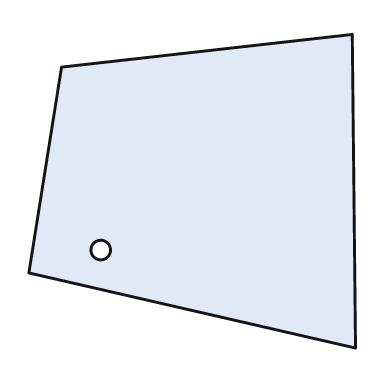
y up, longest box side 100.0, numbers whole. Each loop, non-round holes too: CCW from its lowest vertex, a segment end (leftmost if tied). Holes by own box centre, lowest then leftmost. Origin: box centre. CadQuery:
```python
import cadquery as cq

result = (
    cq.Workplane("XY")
    .moveTo(50.0, -48.0)
    .lineTo(49.0, 48.0)
    .lineTo(-40.0, 38.0)
    .lineTo(-50.0, -25.0)
    .close()
    .moveTo(-28.0, -18.0)
    .circle(3.0)
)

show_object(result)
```